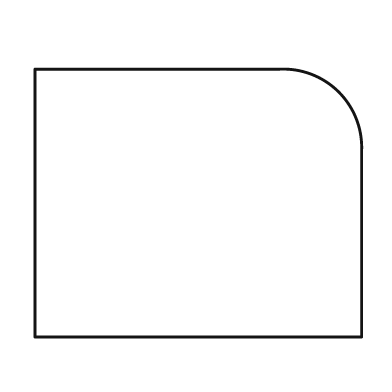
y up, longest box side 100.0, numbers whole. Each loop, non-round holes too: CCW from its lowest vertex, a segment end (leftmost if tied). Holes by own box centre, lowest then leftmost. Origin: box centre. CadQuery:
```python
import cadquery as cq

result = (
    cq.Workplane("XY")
    .moveTo(-50.0, -41.0)
    .lineTo(50.0, -41.0)
    .lineTo(50.0, 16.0)
    .threePointArc((43.0, 34.0), (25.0, 41.0))
    .lineTo(-50.0, 41.0)
    .close()
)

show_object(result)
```